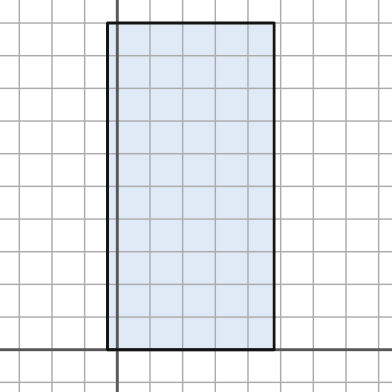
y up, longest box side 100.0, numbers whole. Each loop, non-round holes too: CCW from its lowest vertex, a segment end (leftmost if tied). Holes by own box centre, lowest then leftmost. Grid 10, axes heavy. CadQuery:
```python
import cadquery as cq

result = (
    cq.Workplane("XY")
    .moveTo(-3.0, 0.0)
    .lineTo(48.0, 0.0)
    .lineTo(48.0, 100.0)
    .lineTo(-3.0, 100.0)
    .close()
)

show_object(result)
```